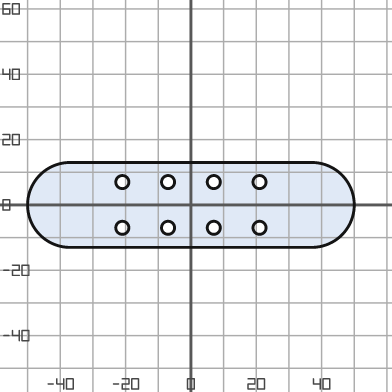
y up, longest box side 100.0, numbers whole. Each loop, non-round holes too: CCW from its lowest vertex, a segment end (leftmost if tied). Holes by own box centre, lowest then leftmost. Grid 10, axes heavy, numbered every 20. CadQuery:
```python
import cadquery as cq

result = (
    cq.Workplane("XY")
    .moveTo(-37.0, -13.0)
    .lineTo(37.0, -13.0)
    .threePointArc((50.0, 0.0), (37.0, 13.0))
    .lineTo(-37.0, 13.0)
    .threePointArc((-50.0, 0.0), (-37.0, -13.0))
    .close()
    .moveTo(-21.0, -7.0)
    .circle(2.0)
    .moveTo(-7.0, -7.0)
    .circle(2.0)
    .moveTo(7.0, -7.0)
    .circle(2.0)
    .moveTo(21.0, -7.0)
    .circle(2.0)
    .moveTo(-21.0, 7.0)
    .circle(2.0)
    .moveTo(-7.0, 7.0)
    .circle(2.0)
    .moveTo(7.0, 7.0)
    .circle(2.0)
    .moveTo(21.0, 7.0)
    .circle(2.0)
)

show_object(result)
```